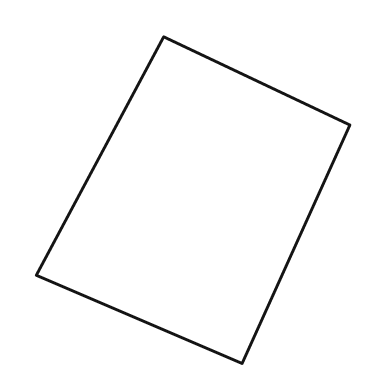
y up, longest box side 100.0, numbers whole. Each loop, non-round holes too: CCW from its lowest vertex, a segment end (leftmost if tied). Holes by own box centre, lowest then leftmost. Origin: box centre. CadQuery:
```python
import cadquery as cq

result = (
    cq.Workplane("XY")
    .moveTo(15.0, -50.0)
    .lineTo(48.0, 23.0)
    .lineTo(-9.0, 50.0)
    .lineTo(-48.0, -23.0)
    .close()
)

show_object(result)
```